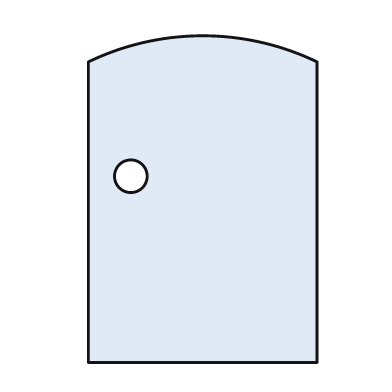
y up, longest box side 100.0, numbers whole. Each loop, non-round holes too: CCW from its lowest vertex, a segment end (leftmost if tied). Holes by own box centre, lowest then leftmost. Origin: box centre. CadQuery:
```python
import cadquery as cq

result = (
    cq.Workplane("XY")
    .moveTo(-35.0, -50.0)
    .lineTo(35.0, -50.0)
    .lineTo(35.0, 42.0)
    .threePointArc((0.0, 50.0), (-35.0, 42.0))
    .close()
    .moveTo(-22.0, 7.0)
    .circle(5.0)
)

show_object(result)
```